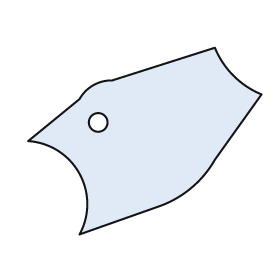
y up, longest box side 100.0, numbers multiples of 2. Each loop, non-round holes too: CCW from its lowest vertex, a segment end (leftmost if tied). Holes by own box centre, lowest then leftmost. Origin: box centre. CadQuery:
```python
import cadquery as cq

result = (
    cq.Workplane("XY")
    .moveTo(-28.0, -40.0)
    .lineTo(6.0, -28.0)
    .threePointArc((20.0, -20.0), (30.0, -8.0))
    .lineTo(50.0, 20.0)
    .threePointArc((38.0, 28.0), (30.0, 40.0))
    .lineTo(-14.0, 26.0)
    .threePointArc((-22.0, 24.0), (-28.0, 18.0))
    .lineTo(-50.0, 0.0)
    .threePointArc((-28.0, -14.0), (-28.0, -40.0))
    .close()
    .moveTo(-20.0, 8.0)
    .circle(4.0)
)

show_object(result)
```